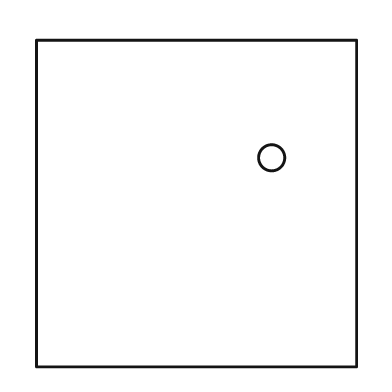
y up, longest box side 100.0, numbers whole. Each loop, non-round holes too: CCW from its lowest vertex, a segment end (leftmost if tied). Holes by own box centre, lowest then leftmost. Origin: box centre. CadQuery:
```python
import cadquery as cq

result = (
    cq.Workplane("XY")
    .moveTo(-49.0, -50.0)
    .lineTo(49.0, -50.0)
    .lineTo(49.0, 50.0)
    .lineTo(-49.0, 50.0)
    .close()
    .moveTo(23.0, 14.0)
    .circle(4.0)
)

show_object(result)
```